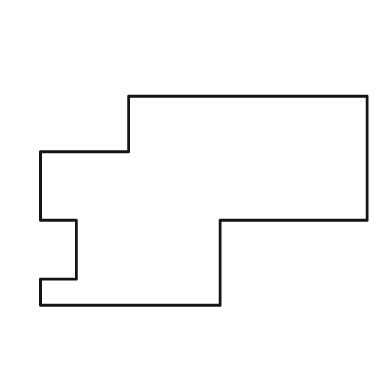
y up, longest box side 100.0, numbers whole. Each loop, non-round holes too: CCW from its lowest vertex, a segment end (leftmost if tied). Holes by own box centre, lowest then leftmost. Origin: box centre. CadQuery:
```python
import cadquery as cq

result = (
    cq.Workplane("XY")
    .moveTo(-50.0, -32.0)
    .lineTo(5.0, -32.0)
    .lineTo(5.0, -6.0)
    .lineTo(50.0, -6.0)
    .lineTo(50.0, 32.0)
    .lineTo(-23.0, 32.0)
    .lineTo(-23.0, 15.0)
    .lineTo(-50.0, 15.0)
    .lineTo(-50.0, -6.0)
    .lineTo(-39.0, -6.0)
    .lineTo(-39.0, -24.0)
    .lineTo(-50.0, -24.0)
    .close()
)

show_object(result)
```